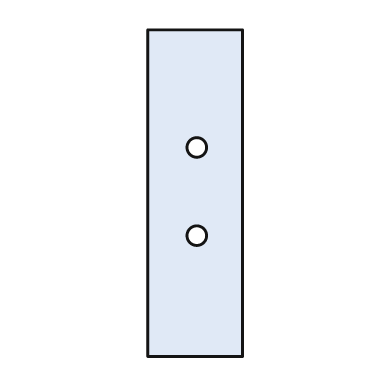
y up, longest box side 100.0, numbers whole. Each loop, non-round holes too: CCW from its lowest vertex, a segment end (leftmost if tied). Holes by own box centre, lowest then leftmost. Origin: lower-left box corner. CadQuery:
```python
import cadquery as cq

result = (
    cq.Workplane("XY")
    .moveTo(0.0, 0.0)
    .lineTo(29.0, 0.0)
    .lineTo(29.0, 100.0)
    .lineTo(0.0, 100.0)
    .close()
    .moveTo(15.0, 37.0)
    .circle(3.0)
    .moveTo(15.0, 64.0)
    .circle(3.0)
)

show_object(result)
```